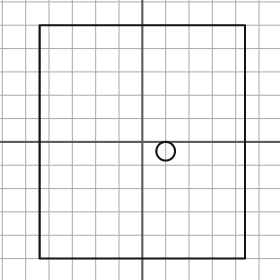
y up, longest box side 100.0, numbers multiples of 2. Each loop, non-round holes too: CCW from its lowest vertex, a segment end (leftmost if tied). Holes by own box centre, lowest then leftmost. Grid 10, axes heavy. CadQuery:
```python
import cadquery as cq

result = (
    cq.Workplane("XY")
    .moveTo(-44.0, -50.0)
    .lineTo(44.0, -50.0)
    .lineTo(44.0, 50.0)
    .lineTo(-44.0, 50.0)
    .close()
    .moveTo(10.0, -4.0)
    .circle(4.0)
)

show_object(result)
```